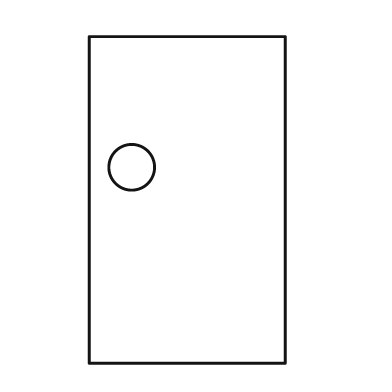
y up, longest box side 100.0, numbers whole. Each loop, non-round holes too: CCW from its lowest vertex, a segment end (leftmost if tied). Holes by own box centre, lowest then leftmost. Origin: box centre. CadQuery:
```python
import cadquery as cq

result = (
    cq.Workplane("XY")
    .moveTo(-30.0, -50.0)
    .lineTo(30.0, -50.0)
    .lineTo(30.0, 50.0)
    .lineTo(-30.0, 50.0)
    .close()
    .moveTo(-17.0, 10.0)
    .circle(7.0)
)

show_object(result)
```